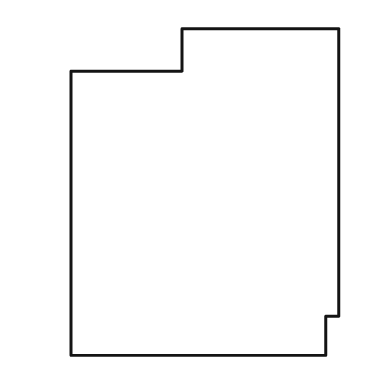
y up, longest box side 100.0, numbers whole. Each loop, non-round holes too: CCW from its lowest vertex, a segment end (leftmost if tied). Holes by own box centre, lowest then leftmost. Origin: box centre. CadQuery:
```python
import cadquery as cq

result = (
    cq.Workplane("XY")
    .moveTo(-41.0, -50.0)
    .lineTo(37.0, -50.0)
    .lineTo(37.0, -38.0)
    .lineTo(41.0, -38.0)
    .lineTo(41.0, 50.0)
    .lineTo(-7.0, 50.0)
    .lineTo(-7.0, 37.0)
    .lineTo(-41.0, 37.0)
    .close()
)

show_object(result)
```